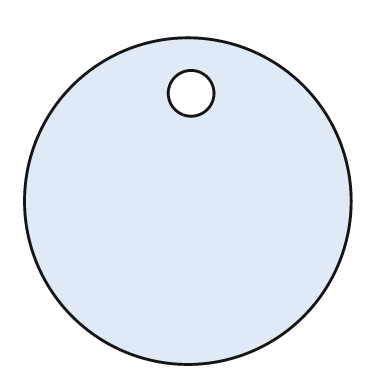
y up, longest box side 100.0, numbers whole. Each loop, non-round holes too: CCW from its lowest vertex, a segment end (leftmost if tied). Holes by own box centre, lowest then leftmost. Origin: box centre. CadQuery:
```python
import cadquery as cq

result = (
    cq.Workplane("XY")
    .moveTo(0.0, 0.0)
    .circle(50.0)
    .moveTo(1.0, 33.0)
    .circle(7.0)
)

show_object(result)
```